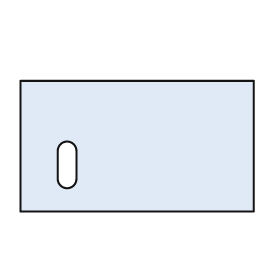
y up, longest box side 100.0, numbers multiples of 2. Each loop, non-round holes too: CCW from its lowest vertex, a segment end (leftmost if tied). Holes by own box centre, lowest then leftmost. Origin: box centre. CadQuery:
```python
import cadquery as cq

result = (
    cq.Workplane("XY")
    .moveTo(-50.0, -28.0)
    .lineTo(50.0, -28.0)
    .lineTo(50.0, 28.0)
    .lineTo(-50.0, 28.0)
    .close()
    .moveTo(-34.0, -14.0)
    .threePointArc((-30.0, -18.0), (-26.0, -14.0))
    .lineTo(-26.0, -2.0)
    .threePointArc((-30.0, 2.0), (-34.0, -2.0))
    .close()
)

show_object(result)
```